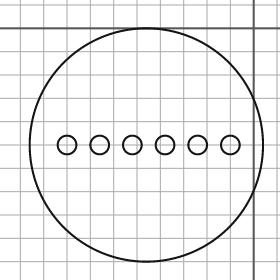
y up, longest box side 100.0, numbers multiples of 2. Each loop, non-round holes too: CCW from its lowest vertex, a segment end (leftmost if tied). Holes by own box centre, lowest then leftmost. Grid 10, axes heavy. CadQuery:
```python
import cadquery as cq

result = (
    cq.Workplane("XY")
    .moveTo(-46.0, -50.0)
    .circle(50.0)
    .moveTo(-80.0, -50.0)
    .circle(4.0)
    .moveTo(-66.0, -50.0)
    .circle(4.0)
    .moveTo(-52.0, -50.0)
    .circle(4.0)
    .moveTo(-38.0, -50.0)
    .circle(4.0)
    .moveTo(-24.0, -50.0)
    .circle(4.0)
    .moveTo(-10.0, -50.0)
    .circle(4.0)
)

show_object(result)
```